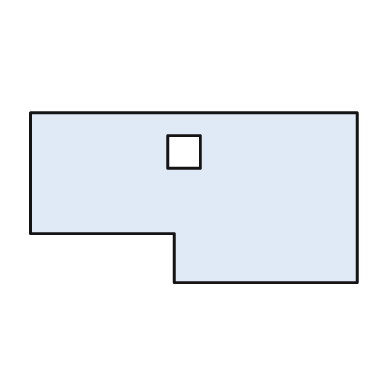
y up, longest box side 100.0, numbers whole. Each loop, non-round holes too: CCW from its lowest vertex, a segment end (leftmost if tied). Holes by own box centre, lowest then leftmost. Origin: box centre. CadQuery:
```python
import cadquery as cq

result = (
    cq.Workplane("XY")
    .moveTo(-6.0, -26.0)
    .lineTo(50.0, -26.0)
    .lineTo(50.0, 26.0)
    .lineTo(-50.0, 26.0)
    .lineTo(-50.0, -11.0)
    .lineTo(-6.0, -11.0)
    .close()
    .moveTo(-8.0, 9.0)
    .lineTo(2.0, 9.0)
    .lineTo(2.0, 19.0)
    .lineTo(-8.0, 19.0)
    .close()
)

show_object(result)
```